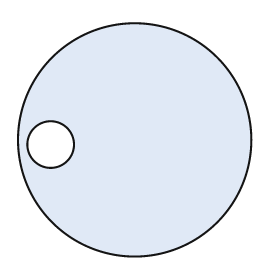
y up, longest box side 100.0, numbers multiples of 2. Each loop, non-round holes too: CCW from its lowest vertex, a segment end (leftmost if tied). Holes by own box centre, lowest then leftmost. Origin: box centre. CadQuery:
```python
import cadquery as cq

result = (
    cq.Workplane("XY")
    .moveTo(0.0, 0.0)
    .circle(50.0)
    .moveTo(-36.0, -2.0)
    .circle(10.0)
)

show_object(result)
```